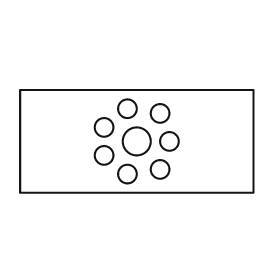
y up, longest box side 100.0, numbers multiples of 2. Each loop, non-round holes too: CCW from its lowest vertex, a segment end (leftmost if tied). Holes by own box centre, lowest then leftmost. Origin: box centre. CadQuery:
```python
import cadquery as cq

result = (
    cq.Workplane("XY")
    .moveTo(-50.0, -22.0)
    .lineTo(50.0, -22.0)
    .lineTo(50.0, 22.0)
    .lineTo(-50.0, 22.0)
    .close()
    .moveTo(-4.0, -14.0)
    .circle(4.0)
    .moveTo(10.0, -12.0)
    .circle(4.0)
    .moveTo(-14.0, -6.0)
    .circle(4.0)
    .moveTo(0.0, 0.0)
    .circle(6.0)
    .moveTo(14.0, 0.0)
    .circle(4.0)
    .moveTo(-14.0, 6.0)
    .circle(4.0)
    .moveTo(10.0, 12.0)
    .circle(4.0)
    .moveTo(-4.0, 14.0)
    .circle(4.0)
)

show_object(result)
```